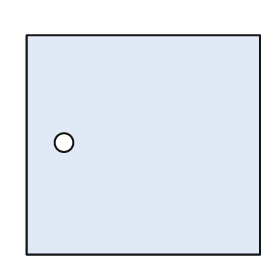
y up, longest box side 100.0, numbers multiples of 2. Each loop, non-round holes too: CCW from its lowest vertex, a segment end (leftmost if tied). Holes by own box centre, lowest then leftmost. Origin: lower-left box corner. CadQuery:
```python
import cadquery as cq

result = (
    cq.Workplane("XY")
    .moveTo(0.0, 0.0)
    .lineTo(100.0, 0.0)
    .lineTo(100.0, 94.0)
    .lineTo(0.0, 94.0)
    .close()
    .moveTo(16.0, 48.0)
    .circle(4.0)
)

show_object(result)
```